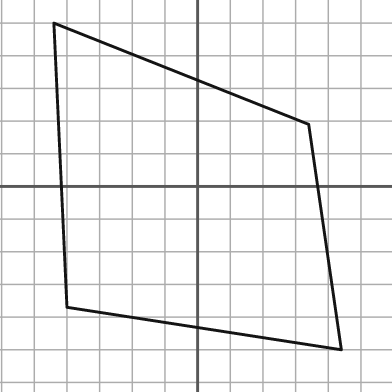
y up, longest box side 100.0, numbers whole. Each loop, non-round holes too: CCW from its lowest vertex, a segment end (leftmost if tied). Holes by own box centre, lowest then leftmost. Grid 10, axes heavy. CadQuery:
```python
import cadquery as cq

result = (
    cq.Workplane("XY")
    .moveTo(44.0, -50.0)
    .lineTo(34.0, 19.0)
    .lineTo(-44.0, 50.0)
    .lineTo(-40.0, -37.0)
    .close()
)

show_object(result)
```